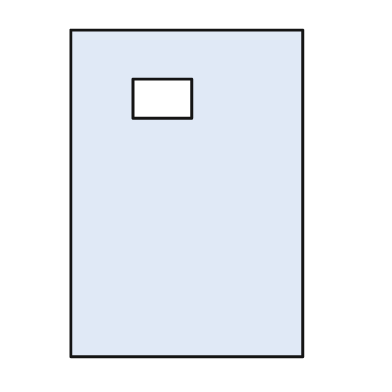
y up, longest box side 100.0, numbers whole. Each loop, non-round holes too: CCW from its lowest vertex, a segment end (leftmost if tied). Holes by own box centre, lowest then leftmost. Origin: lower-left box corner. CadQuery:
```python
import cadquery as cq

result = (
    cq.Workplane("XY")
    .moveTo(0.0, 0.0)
    .lineTo(71.0, 0.0)
    .lineTo(71.0, 100.0)
    .lineTo(0.0, 100.0)
    .close()
    .moveTo(19.0, 73.0)
    .lineTo(37.0, 73.0)
    .lineTo(37.0, 85.0)
    .lineTo(19.0, 85.0)
    .close()
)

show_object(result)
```